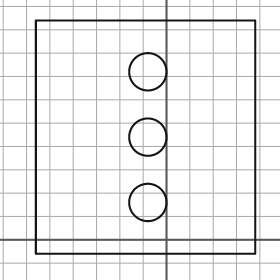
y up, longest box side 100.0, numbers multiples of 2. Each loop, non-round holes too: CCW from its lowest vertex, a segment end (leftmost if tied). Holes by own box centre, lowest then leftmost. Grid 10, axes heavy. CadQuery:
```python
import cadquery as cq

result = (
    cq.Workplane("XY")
    .moveTo(-56.0, -6.0)
    .lineTo(38.0, -6.0)
    .lineTo(38.0, 94.0)
    .lineTo(-56.0, 94.0)
    .close()
    .moveTo(-8.0, 16.0)
    .circle(8.0)
    .moveTo(-8.0, 44.0)
    .circle(8.0)
    .moveTo(-8.0, 72.0)
    .circle(8.0)
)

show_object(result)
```